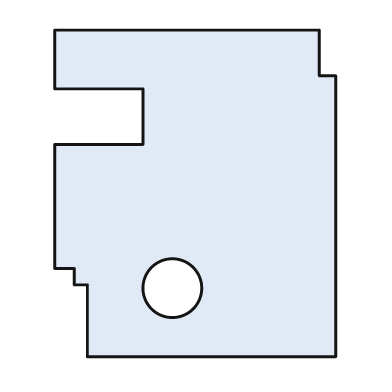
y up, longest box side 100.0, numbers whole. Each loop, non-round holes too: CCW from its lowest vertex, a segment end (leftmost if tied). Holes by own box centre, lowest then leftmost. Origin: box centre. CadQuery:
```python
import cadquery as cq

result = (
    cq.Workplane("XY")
    .moveTo(-33.0, -50.0)
    .lineTo(43.0, -50.0)
    .lineTo(43.0, 36.0)
    .lineTo(38.0, 36.0)
    .lineTo(38.0, 50.0)
    .lineTo(-43.0, 50.0)
    .lineTo(-43.0, 32.0)
    .lineTo(-16.0, 32.0)
    .lineTo(-16.0, 15.0)
    .lineTo(-43.0, 15.0)
    .lineTo(-43.0, -23.0)
    .lineTo(-37.0, -23.0)
    .lineTo(-37.0, -28.0)
    .lineTo(-33.0, -28.0)
    .close()
    .moveTo(-7.0, -29.0)
    .circle(9.0)
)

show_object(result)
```